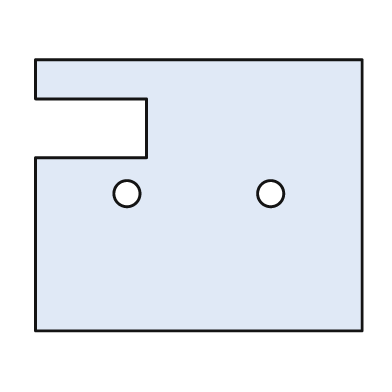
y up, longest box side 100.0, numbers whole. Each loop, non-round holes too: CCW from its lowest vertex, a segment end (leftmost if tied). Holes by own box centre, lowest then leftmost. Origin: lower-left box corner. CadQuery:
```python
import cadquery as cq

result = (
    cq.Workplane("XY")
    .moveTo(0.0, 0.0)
    .lineTo(100.0, 0.0)
    .lineTo(100.0, 83.0)
    .lineTo(0.0, 83.0)
    .lineTo(0.0, 71.0)
    .lineTo(34.0, 71.0)
    .lineTo(34.0, 53.0)
    .lineTo(0.0, 53.0)
    .close()
    .moveTo(28.0, 42.0)
    .circle(4.0)
    .moveTo(72.0, 42.0)
    .circle(4.0)
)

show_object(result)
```